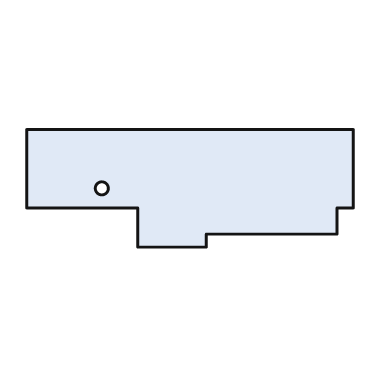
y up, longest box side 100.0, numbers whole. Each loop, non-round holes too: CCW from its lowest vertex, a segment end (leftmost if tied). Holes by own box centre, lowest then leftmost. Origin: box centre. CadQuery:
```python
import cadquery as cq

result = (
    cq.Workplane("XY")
    .moveTo(-16.0, -18.0)
    .lineTo(5.0, -18.0)
    .lineTo(5.0, -14.0)
    .lineTo(45.0, -14.0)
    .lineTo(45.0, -6.0)
    .lineTo(50.0, -6.0)
    .lineTo(50.0, 18.0)
    .lineTo(-50.0, 18.0)
    .lineTo(-50.0, -6.0)
    .lineTo(-16.0, -6.0)
    .close()
    .moveTo(-27.0, 0.0)
    .circle(2.0)
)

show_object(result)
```